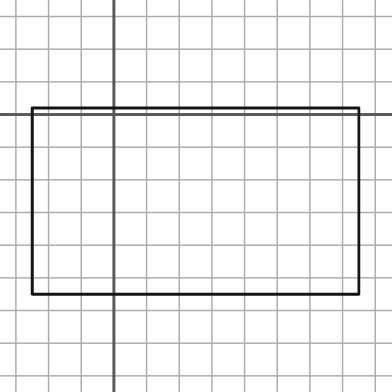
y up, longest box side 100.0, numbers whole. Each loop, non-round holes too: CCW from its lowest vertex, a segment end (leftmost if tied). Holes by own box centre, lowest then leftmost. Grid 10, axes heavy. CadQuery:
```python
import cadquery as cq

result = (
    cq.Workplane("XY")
    .moveTo(-25.0, -55.0)
    .lineTo(75.0, -55.0)
    .lineTo(75.0, 2.0)
    .lineTo(-25.0, 2.0)
    .close()
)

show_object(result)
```